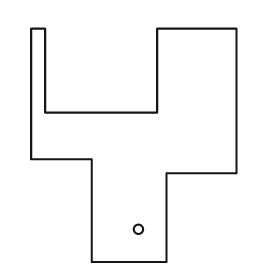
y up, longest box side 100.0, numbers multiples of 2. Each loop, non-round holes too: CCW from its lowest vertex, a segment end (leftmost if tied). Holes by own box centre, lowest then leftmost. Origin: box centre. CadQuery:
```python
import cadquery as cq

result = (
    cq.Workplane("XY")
    .moveTo(-18.0, -50.0)
    .lineTo(14.0, -50.0)
    .lineTo(14.0, -12.0)
    .lineTo(44.0, -12.0)
    .lineTo(44.0, 50.0)
    .lineTo(10.0, 50.0)
    .lineTo(10.0, 14.0)
    .lineTo(-38.0, 14.0)
    .lineTo(-38.0, 50.0)
    .lineTo(-44.0, 50.0)
    .lineTo(-44.0, -6.0)
    .lineTo(-18.0, -6.0)
    .close()
    .moveTo(2.0, -36.0)
    .circle(2.0)
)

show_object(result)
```